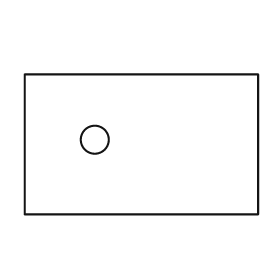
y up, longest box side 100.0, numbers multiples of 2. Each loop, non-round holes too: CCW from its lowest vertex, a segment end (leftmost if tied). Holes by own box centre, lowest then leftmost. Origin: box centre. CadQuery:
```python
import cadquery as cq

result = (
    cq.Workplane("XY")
    .moveTo(-50.0, -30.0)
    .lineTo(50.0, -30.0)
    .lineTo(50.0, 30.0)
    .lineTo(-50.0, 30.0)
    .close()
    .moveTo(-20.0, 2.0)
    .circle(6.0)
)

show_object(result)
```